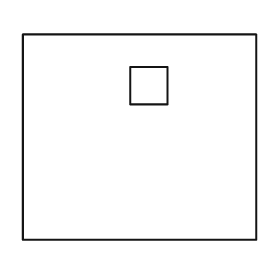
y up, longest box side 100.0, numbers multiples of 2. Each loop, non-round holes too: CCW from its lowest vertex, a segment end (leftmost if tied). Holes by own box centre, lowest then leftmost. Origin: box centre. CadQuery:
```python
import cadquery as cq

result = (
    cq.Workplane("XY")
    .moveTo(-50.0, -44.0)
    .lineTo(50.0, -44.0)
    .lineTo(50.0, 44.0)
    .lineTo(-50.0, 44.0)
    .close()
    .moveTo(-4.0, 14.0)
    .lineTo(12.0, 14.0)
    .lineTo(12.0, 30.0)
    .lineTo(-4.0, 30.0)
    .close()
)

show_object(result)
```